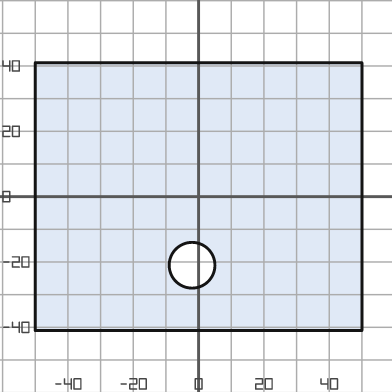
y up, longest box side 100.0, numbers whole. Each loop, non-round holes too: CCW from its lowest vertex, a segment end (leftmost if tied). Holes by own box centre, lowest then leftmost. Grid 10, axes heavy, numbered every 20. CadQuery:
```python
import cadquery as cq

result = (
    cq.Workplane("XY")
    .moveTo(-50.0, -41.0)
    .lineTo(50.0, -41.0)
    .lineTo(50.0, 41.0)
    .lineTo(-50.0, 41.0)
    .close()
    .moveTo(-2.0, -21.0)
    .circle(7.0)
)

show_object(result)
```